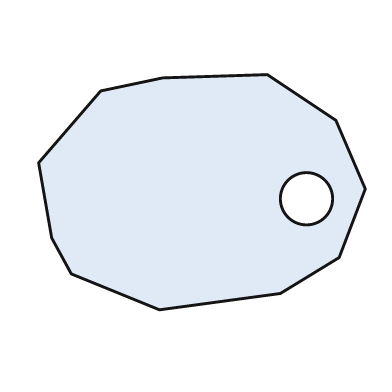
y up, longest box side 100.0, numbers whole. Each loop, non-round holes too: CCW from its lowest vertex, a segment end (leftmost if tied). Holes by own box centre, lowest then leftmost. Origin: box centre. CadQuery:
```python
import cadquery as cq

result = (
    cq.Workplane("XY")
    .moveTo(-13.0, -36.0)
    .lineTo(24.0, -31.0)
    .lineTo(42.0, -20.0)
    .lineTo(50.0, 1.0)
    .lineTo(41.0, 22.0)
    .lineTo(20.0, 36.0)
    .lineTo(-12.0, 35.0)
    .lineTo(-31.0, 31.0)
    .lineTo(-50.0, 9.0)
    .lineTo(-46.0, -14.0)
    .lineTo(-40.0, -25.0)
    .close()
    .moveTo(32.0, -2.0)
    .circle(8.0)
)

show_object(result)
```